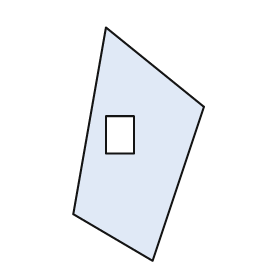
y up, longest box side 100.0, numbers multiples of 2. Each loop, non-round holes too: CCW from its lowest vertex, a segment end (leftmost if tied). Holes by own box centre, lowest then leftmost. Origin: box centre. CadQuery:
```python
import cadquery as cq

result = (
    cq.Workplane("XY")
    .moveTo(6.0, -50.0)
    .lineTo(28.0, 16.0)
    .lineTo(-14.0, 50.0)
    .lineTo(-28.0, -30.0)
    .close()
    .moveTo(-14.0, -4.0)
    .lineTo(-2.0, -4.0)
    .lineTo(-2.0, 12.0)
    .lineTo(-14.0, 12.0)
    .close()
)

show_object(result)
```